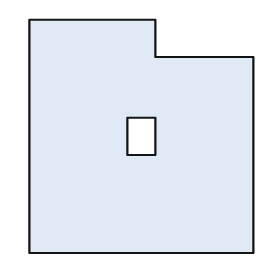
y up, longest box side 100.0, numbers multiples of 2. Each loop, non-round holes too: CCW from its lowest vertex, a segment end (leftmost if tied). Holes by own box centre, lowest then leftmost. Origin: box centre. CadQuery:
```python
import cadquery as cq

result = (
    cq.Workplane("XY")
    .moveTo(-48.0, -50.0)
    .lineTo(48.0, -50.0)
    .lineTo(48.0, 34.0)
    .lineTo(6.0, 34.0)
    .lineTo(6.0, 50.0)
    .lineTo(-48.0, 50.0)
    .close()
    .moveTo(-6.0, -8.0)
    .lineTo(6.0, -8.0)
    .lineTo(6.0, 8.0)
    .lineTo(-6.0, 8.0)
    .close()
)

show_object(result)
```